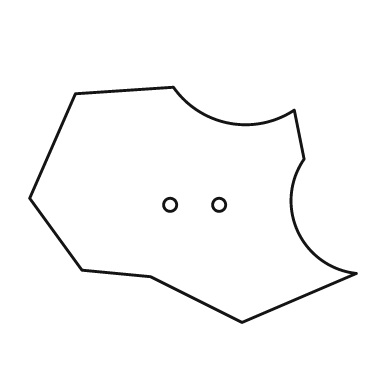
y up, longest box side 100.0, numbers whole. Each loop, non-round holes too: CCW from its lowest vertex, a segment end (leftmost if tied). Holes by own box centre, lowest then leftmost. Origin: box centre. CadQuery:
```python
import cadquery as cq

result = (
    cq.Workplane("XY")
    .moveTo(15.0, -36.0)
    .lineTo(50.0, -21.0)
    .threePointArc((32.0, -8.0), (34.0, 14.0))
    .lineTo(31.0, 29.0)
    .threePointArc((11.0, 25.0), (-6.0, 36.0))
    .lineTo(-36.0, 34.0)
    .lineTo(-50.0, 2.0)
    .lineTo(-34.0, -20.0)
    .lineTo(-13.0, -22.0)
    .close()
    .moveTo(-7.0, 0.0)
    .circle(2.0)
    .moveTo(8.0, 0.0)
    .circle(2.0)
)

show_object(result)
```